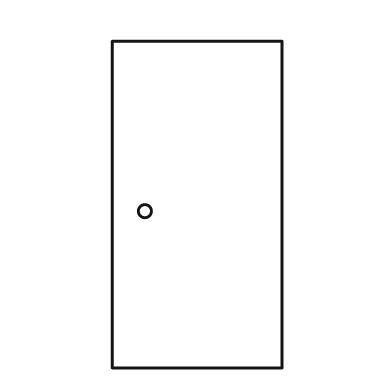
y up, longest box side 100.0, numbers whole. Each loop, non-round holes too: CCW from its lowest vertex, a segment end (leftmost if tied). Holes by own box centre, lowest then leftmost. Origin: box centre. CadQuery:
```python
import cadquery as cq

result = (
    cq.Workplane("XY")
    .moveTo(-26.0, -50.0)
    .lineTo(26.0, -50.0)
    .lineTo(26.0, 50.0)
    .lineTo(-26.0, 50.0)
    .close()
    .moveTo(-16.0, -2.0)
    .circle(2.0)
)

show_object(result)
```